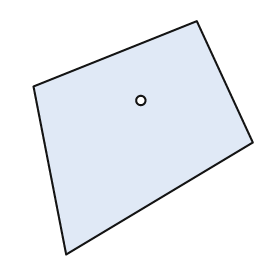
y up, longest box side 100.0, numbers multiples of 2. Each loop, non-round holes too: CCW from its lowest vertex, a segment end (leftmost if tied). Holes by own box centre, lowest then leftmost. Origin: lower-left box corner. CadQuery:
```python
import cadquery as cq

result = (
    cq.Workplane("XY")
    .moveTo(14.0, 0.0)
    .lineTo(94.0, 48.0)
    .lineTo(70.0, 100.0)
    .lineTo(0.0, 72.0)
    .close()
    .moveTo(46.0, 66.0)
    .circle(2.0)
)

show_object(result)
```